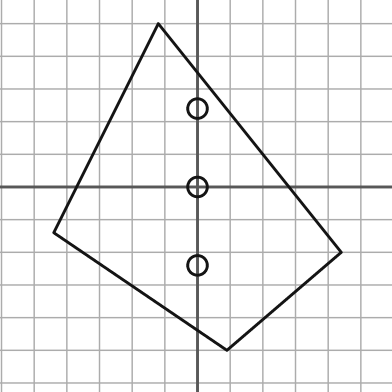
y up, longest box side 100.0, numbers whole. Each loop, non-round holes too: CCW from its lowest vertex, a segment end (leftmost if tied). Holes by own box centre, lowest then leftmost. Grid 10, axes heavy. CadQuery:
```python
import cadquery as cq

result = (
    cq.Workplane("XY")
    .moveTo(9.0, -50.0)
    .lineTo(44.0, -20.0)
    .lineTo(-12.0, 50.0)
    .lineTo(-44.0, -14.0)
    .close()
    .moveTo(0.0, -24.0)
    .circle(3.0)
    .moveTo(0.0, 0.0)
    .circle(3.0)
    .moveTo(0.0, 24.0)
    .circle(3.0)
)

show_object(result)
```